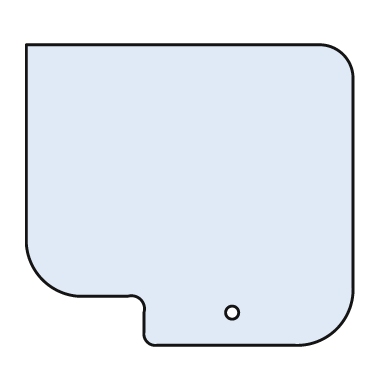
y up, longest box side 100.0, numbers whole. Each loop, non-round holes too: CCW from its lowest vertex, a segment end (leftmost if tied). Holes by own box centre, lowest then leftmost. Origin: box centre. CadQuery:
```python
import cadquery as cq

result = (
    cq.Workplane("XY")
    .moveTo(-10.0, -46.0)
    .lineTo(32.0, -46.0)
    .threePointArc((45.0, -41.0), (50.0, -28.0))
    .lineTo(50.0, 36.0)
    .threePointArc((47.0, 43.0), (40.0, 46.0))
    .lineTo(-50.0, 46.0)
    .lineTo(-50.0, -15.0)
    .threePointArc((-45.0, -26.0), (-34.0, -31.0))
    .lineTo(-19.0, -31.0)
    .threePointArc((-15.0, -32.0), (-14.0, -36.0))
    .lineTo(-14.0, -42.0)
    .threePointArc((-13.0, -45.0), (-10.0, -46.0))
    .close()
    .moveTo(13.0, -36.0)
    .circle(2.0)
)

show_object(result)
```